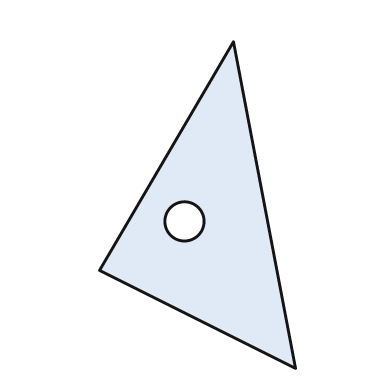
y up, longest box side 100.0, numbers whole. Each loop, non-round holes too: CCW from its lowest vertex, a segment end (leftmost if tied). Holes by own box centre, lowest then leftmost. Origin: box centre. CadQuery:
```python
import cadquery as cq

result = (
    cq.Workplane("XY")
    .moveTo(30.0, -50.0)
    .lineTo(11.0, 50.0)
    .lineTo(-30.0, -20.0)
    .close()
    .moveTo(-4.0, -5.0)
    .circle(6.0)
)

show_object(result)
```